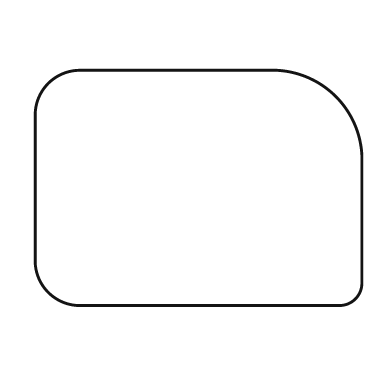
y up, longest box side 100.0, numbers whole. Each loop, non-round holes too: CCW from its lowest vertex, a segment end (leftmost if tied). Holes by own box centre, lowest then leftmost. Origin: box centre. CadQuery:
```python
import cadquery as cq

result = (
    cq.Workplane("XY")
    .moveTo(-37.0, -36.0)
    .lineTo(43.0, -36.0)
    .threePointArc((48.0, -34.0), (50.0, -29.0))
    .lineTo(50.0, 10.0)
    .threePointArc((42.0, 28.0), (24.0, 36.0))
    .lineTo(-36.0, 36.0)
    .threePointArc((-46.0, 32.0), (-50.0, 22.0))
    .lineTo(-50.0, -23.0)
    .threePointArc((-46.0, -32.0), (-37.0, -36.0))
    .close()
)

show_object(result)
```